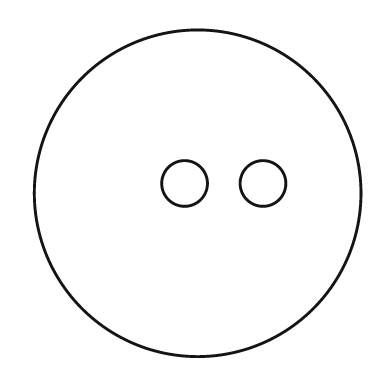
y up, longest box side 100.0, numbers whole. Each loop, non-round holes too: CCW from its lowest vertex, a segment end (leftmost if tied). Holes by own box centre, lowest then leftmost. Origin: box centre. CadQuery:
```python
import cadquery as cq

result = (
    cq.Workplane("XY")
    .moveTo(0.0, 0.0)
    .circle(50.0)
    .moveTo(-4.0, 3.0)
    .circle(7.0)
    .moveTo(20.0, 3.0)
    .circle(7.0)
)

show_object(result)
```